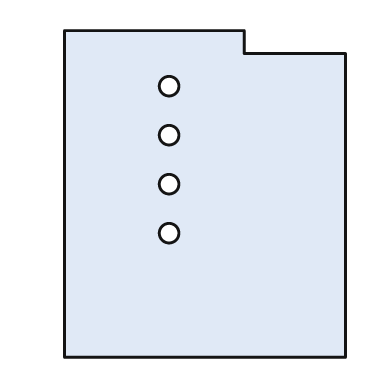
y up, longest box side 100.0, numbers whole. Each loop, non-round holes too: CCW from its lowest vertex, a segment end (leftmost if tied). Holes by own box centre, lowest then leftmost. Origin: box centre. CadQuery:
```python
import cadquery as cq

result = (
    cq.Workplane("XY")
    .moveTo(-43.0, -50.0)
    .lineTo(43.0, -50.0)
    .lineTo(43.0, 43.0)
    .lineTo(12.0, 43.0)
    .lineTo(12.0, 50.0)
    .lineTo(-43.0, 50.0)
    .close()
    .moveTo(-11.0, -12.0)
    .circle(3.0)
    .moveTo(-11.0, 3.0)
    .circle(3.0)
    .moveTo(-11.0, 18.0)
    .circle(3.0)
    .moveTo(-11.0, 33.0)
    .circle(3.0)
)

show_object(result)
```